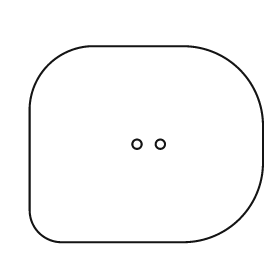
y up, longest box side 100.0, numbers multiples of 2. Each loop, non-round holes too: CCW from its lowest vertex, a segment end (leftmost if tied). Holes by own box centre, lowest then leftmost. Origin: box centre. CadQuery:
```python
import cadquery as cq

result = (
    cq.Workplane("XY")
    .moveTo(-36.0, -42.0)
    .lineTo(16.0, -42.0)
    .threePointArc((40.0, -32.0), (50.0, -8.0))
    .lineTo(50.0, 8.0)
    .threePointArc((40.0, 32.0), (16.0, 42.0))
    .lineTo(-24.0, 42.0)
    .threePointArc((-42.0, 34.0), (-50.0, 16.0))
    .lineTo(-50.0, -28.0)
    .threePointArc((-46.0, -38.0), (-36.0, -42.0))
    .close()
    .moveTo(-4.0, 0.0)
    .circle(2.0)
    .moveTo(6.0, 0.0)
    .circle(2.0)
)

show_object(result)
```